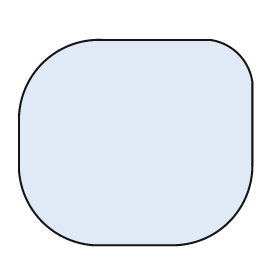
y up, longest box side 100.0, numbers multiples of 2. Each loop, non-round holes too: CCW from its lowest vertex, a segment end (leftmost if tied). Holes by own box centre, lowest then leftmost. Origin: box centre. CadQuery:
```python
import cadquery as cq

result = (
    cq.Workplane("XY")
    .moveTo(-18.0, -44.0)
    .lineTo(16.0, -44.0)
    .threePointArc((40.0, -34.0), (50.0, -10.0))
    .lineTo(50.0, 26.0)
    .threePointArc((44.0, 38.0), (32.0, 44.0))
    .lineTo(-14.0, 44.0)
    .threePointArc((-40.0, 34.0), (-50.0, 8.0))
    .lineTo(-50.0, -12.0)
    .threePointArc((-40.0, -34.0), (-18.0, -44.0))
    .close()
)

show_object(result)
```